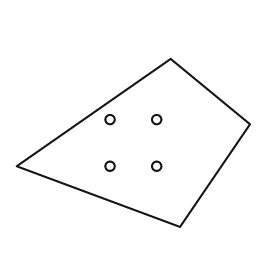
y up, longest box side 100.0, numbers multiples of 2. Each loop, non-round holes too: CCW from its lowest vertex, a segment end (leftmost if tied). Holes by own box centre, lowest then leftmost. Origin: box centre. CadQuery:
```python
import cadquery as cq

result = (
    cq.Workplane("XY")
    .moveTo(20.0, -36.0)
    .lineTo(50.0, 8.0)
    .lineTo(16.0, 36.0)
    .lineTo(-50.0, -10.0)
    .close()
    .moveTo(-10.0, -10.0)
    .circle(2.0)
    .moveTo(10.0, -10.0)
    .circle(2.0)
    .moveTo(-10.0, 10.0)
    .circle(2.0)
    .moveTo(10.0, 10.0)
    .circle(2.0)
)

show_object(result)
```